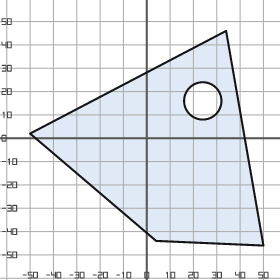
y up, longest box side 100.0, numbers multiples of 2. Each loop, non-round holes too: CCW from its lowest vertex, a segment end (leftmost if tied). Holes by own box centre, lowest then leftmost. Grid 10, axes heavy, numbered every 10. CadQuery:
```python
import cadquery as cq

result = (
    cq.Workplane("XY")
    .moveTo(50.0, -46.0)
    .lineTo(34.0, 46.0)
    .lineTo(-50.0, 2.0)
    .lineTo(4.0, -44.0)
    .close()
    .moveTo(24.0, 16.0)
    .circle(8.0)
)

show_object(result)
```